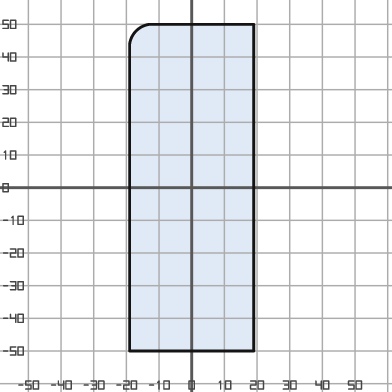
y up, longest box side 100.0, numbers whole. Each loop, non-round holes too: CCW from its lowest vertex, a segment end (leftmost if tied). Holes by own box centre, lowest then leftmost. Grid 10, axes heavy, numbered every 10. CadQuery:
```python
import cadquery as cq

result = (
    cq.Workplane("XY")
    .moveTo(-19.0, -50.0)
    .lineTo(19.0, -50.0)
    .lineTo(19.0, 50.0)
    .lineTo(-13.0, 50.0)
    .threePointArc((-17.0, 48.0), (-19.0, 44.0))
    .close()
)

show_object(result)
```